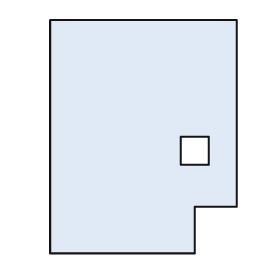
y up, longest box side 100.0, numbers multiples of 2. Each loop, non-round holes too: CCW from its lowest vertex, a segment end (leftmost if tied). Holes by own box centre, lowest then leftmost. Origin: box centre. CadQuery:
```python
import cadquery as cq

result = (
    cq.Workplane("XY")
    .moveTo(-40.0, -50.0)
    .lineTo(22.0, -50.0)
    .lineTo(22.0, -30.0)
    .lineTo(40.0, -30.0)
    .lineTo(40.0, 50.0)
    .lineTo(-40.0, 50.0)
    .close()
    .moveTo(16.0, -12.0)
    .lineTo(28.0, -12.0)
    .lineTo(28.0, 0.0)
    .lineTo(16.0, 0.0)
    .close()
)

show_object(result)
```